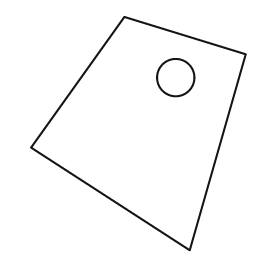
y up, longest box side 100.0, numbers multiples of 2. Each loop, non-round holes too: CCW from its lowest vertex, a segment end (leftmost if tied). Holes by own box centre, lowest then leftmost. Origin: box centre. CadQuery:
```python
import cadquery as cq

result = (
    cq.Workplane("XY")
    .moveTo(22.0, -50.0)
    .lineTo(46.0, 34.0)
    .lineTo(-6.0, 50.0)
    .lineTo(-46.0, -6.0)
    .close()
    .moveTo(16.0, 24.0)
    .circle(8.0)
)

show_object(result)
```